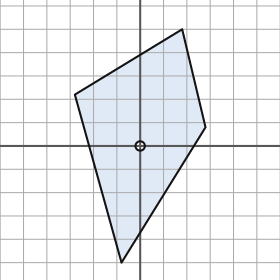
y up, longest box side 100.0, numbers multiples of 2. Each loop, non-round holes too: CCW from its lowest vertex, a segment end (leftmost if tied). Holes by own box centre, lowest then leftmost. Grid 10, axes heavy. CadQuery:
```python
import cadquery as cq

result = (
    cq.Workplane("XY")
    .moveTo(-8.0, -50.0)
    .lineTo(28.0, 8.0)
    .lineTo(18.0, 50.0)
    .lineTo(-28.0, 22.0)
    .close()
    .moveTo(0.0, 0.0)
    .circle(2.0)
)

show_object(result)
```